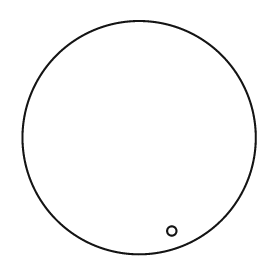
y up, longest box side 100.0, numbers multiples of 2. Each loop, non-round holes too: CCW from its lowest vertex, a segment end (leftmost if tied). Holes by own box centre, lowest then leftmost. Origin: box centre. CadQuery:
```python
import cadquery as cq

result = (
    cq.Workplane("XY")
    .moveTo(0.0, 0.0)
    .circle(50.0)
    .moveTo(14.0, -40.0)
    .circle(2.0)
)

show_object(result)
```